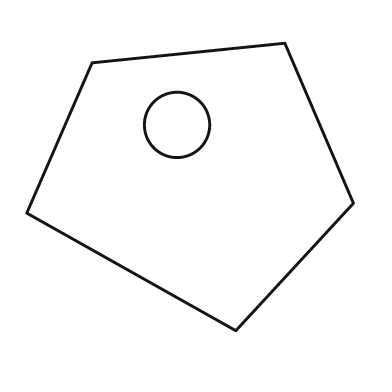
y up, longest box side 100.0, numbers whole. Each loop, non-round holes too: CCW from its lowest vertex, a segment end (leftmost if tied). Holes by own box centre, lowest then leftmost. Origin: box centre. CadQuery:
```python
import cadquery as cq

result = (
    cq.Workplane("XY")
    .moveTo(14.0, -44.0)
    .lineTo(50.0, -5.0)
    .lineTo(29.0, 44.0)
    .lineTo(-30.0, 38.0)
    .lineTo(-50.0, -8.0)
    .close()
    .moveTo(-4.0, 19.0)
    .circle(10.0)
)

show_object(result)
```